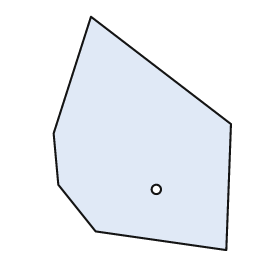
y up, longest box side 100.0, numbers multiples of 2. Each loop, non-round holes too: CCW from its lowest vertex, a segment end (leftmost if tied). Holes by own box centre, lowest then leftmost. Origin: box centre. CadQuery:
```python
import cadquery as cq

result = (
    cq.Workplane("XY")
    .moveTo(36.0, -50.0)
    .lineTo(38.0, 4.0)
    .lineTo(-22.0, 50.0)
    .lineTo(-38.0, 0.0)
    .lineTo(-36.0, -22.0)
    .lineTo(-20.0, -42.0)
    .close()
    .moveTo(6.0, -24.0)
    .circle(2.0)
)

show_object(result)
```